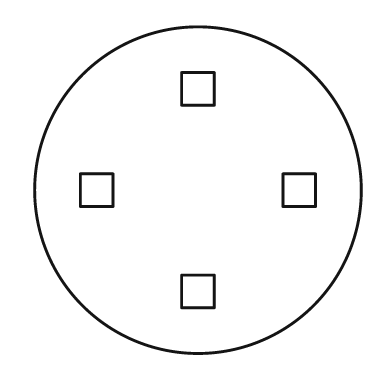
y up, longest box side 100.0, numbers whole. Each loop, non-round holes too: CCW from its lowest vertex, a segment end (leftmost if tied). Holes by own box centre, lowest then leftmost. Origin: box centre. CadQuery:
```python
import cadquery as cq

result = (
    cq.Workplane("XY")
    .moveTo(0.0, 0.0)
    .circle(50.0)
    .moveTo(-5.0, -36.0)
    .lineTo(5.0, -36.0)
    .lineTo(5.0, -26.0)
    .lineTo(-5.0, -26.0)
    .close()
    .moveTo(-36.0, -5.0)
    .lineTo(-26.0, -5.0)
    .lineTo(-26.0, 5.0)
    .lineTo(-36.0, 5.0)
    .close()
    .moveTo(26.0, -5.0)
    .lineTo(36.0, -5.0)
    .lineTo(36.0, 5.0)
    .lineTo(26.0, 5.0)
    .close()
    .moveTo(-5.0, 26.0)
    .lineTo(5.0, 26.0)
    .lineTo(5.0, 36.0)
    .lineTo(-5.0, 36.0)
    .close()
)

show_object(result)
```